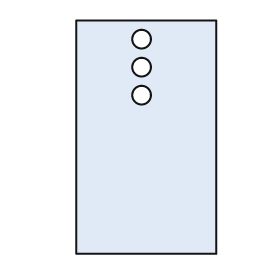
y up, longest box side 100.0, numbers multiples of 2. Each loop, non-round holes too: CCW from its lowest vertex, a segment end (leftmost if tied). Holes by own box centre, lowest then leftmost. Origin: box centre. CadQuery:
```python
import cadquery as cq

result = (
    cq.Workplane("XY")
    .moveTo(-30.0, -50.0)
    .lineTo(30.0, -50.0)
    .lineTo(30.0, 50.0)
    .lineTo(-30.0, 50.0)
    .close()
    .moveTo(-2.0, 18.0)
    .circle(4.0)
    .moveTo(-2.0, 30.0)
    .circle(4.0)
    .moveTo(-2.0, 42.0)
    .circle(4.0)
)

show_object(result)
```